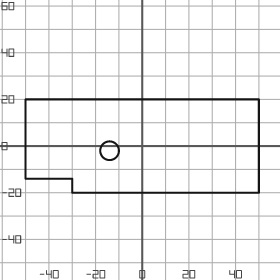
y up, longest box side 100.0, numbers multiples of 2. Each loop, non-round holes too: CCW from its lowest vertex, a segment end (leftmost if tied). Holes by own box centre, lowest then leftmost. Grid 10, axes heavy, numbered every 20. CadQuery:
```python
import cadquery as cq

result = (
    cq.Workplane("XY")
    .moveTo(-30.0, -20.0)
    .lineTo(50.0, -20.0)
    .lineTo(50.0, 20.0)
    .lineTo(-50.0, 20.0)
    .lineTo(-50.0, -14.0)
    .lineTo(-30.0, -14.0)
    .close()
    .moveTo(-14.0, -2.0)
    .circle(4.0)
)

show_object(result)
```